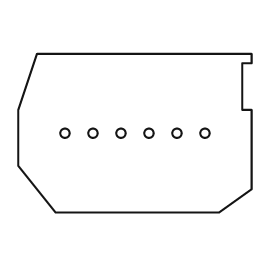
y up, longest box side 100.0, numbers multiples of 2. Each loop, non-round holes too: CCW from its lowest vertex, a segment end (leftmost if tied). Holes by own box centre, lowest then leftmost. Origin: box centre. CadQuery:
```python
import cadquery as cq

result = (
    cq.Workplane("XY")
    .moveTo(-34.0, -34.0)
    .lineTo(36.0, -34.0)
    .lineTo(50.0, -24.0)
    .lineTo(50.0, 10.0)
    .lineTo(46.0, 10.0)
    .lineTo(46.0, 30.0)
    .lineTo(50.0, 30.0)
    .lineTo(50.0, 34.0)
    .lineTo(-42.0, 34.0)
    .lineTo(-50.0, 10.0)
    .lineTo(-50.0, -14.0)
    .close()
    .moveTo(-30.0, 0.0)
    .circle(2.0)
    .moveTo(-18.0, 0.0)
    .circle(2.0)
    .moveTo(-6.0, 0.0)
    .circle(2.0)
    .moveTo(6.0, 0.0)
    .circle(2.0)
    .moveTo(18.0, 0.0)
    .circle(2.0)
    .moveTo(30.0, 0.0)
    .circle(2.0)
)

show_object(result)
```